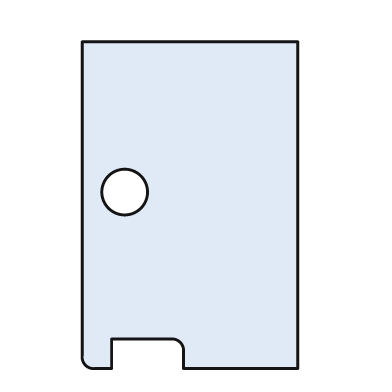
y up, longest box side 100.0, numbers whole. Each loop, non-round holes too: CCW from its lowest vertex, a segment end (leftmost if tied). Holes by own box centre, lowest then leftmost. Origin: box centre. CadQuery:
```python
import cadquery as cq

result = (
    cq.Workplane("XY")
    .moveTo(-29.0, -50.0)
    .lineTo(-24.0, -50.0)
    .lineTo(-24.0, -41.0)
    .lineTo(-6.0, -41.0)
    .threePointArc((-3.0, -42.0), (-2.0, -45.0))
    .lineTo(-2.0, -50.0)
    .lineTo(33.0, -50.0)
    .lineTo(33.0, 50.0)
    .lineTo(-33.0, 50.0)
    .lineTo(-33.0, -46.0)
    .threePointArc((-32.0, -49.0), (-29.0, -50.0))
    .close()
    .moveTo(-20.0, 4.0)
    .circle(7.0)
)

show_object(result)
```